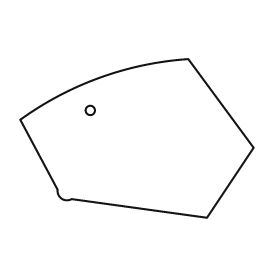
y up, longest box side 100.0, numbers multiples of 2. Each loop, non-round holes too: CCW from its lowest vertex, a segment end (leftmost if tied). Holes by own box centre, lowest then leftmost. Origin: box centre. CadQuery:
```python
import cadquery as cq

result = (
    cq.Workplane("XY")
    .moveTo(30.0, -34.0)
    .lineTo(50.0, -4.0)
    .lineTo(22.0, 34.0)
    .threePointArc((-16.0, 26.0), (-50.0, 8.0))
    .lineTo(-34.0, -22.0)
    .threePointArc((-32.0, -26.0), (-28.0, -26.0))
    .close()
    .moveTo(-20.0, 12.0)
    .circle(2.0)
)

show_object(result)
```